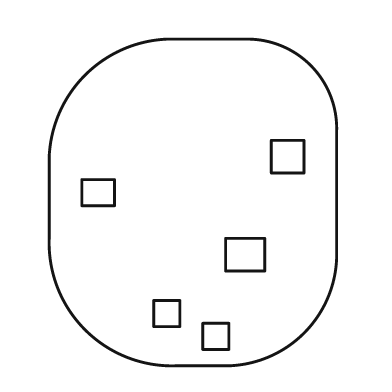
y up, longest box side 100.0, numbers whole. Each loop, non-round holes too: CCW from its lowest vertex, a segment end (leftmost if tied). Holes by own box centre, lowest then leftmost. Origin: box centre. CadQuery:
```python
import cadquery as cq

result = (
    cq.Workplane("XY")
    .moveTo(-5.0, -50.0)
    .lineTo(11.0, -50.0)
    .threePointArc((34.0, -40.0), (44.0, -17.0))
    .lineTo(44.0, 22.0)
    .threePointArc((36.0, 42.0), (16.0, 50.0))
    .lineTo(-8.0, 50.0)
    .threePointArc((-33.0, 39.0), (-44.0, 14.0))
    .lineTo(-44.0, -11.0)
    .threePointArc((-33.0, -39.0), (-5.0, -50.0))
    .close()
    .moveTo(3.0, -45.0)
    .lineTo(11.0, -45.0)
    .lineTo(11.0, -37.0)
    .lineTo(3.0, -37.0)
    .close()
    .moveTo(-12.0, -38.0)
    .lineTo(-4.0, -38.0)
    .lineTo(-4.0, -30.0)
    .lineTo(-12.0, -30.0)
    .close()
    .moveTo(10.0, -21.0)
    .lineTo(22.0, -21.0)
    .lineTo(22.0, -11.0)
    .lineTo(10.0, -11.0)
    .close()
    .moveTo(-34.0, -1.0)
    .lineTo(-24.0, -1.0)
    .lineTo(-24.0, 7.0)
    .lineTo(-34.0, 7.0)
    .close()
    .moveTo(24.0, 9.0)
    .lineTo(34.0, 9.0)
    .lineTo(34.0, 19.0)
    .lineTo(24.0, 19.0)
    .close()
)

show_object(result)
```